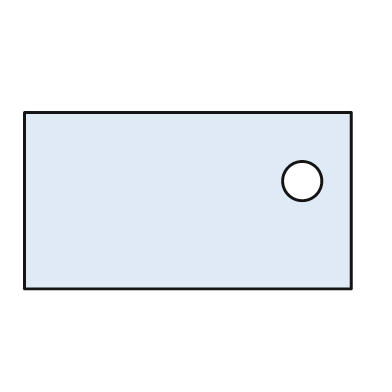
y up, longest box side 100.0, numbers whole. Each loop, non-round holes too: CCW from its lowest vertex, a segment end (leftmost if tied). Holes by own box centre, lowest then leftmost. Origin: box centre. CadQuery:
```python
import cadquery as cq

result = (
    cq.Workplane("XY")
    .moveTo(-50.0, -27.0)
    .lineTo(50.0, -27.0)
    .lineTo(50.0, 27.0)
    .lineTo(-50.0, 27.0)
    .close()
    .moveTo(35.0, 6.0)
    .circle(6.0)
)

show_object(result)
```